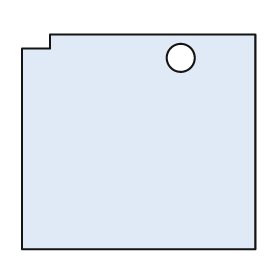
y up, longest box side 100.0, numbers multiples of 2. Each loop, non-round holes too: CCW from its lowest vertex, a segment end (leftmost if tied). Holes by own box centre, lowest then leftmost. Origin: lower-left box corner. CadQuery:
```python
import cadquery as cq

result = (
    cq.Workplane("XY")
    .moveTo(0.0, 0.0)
    .lineTo(100.0, 0.0)
    .lineTo(100.0, 92.0)
    .lineTo(12.0, 92.0)
    .lineTo(12.0, 86.0)
    .lineTo(0.0, 86.0)
    .close()
    .moveTo(68.0, 82.0)
    .circle(6.0)
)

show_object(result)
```